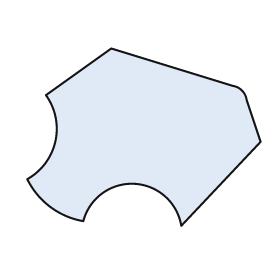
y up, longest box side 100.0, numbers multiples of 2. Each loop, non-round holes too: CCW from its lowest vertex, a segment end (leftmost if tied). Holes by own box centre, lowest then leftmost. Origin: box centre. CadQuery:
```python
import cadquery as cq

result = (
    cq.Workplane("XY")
    .moveTo(16.0, -38.0)
    .lineTo(50.0, -2.0)
    .lineTo(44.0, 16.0)
    .threePointArc((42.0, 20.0), (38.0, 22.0))
    .lineTo(-14.0, 38.0)
    .lineTo(-42.0, 18.0)
    .threePointArc((-38.0, -2.0), (-50.0, -18.0))
    .threePointArc((-40.0, -30.0), (-26.0, -36.0))
    .threePointArc((-4.0, -20.0), (16.0, -38.0))
    .close()
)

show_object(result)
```